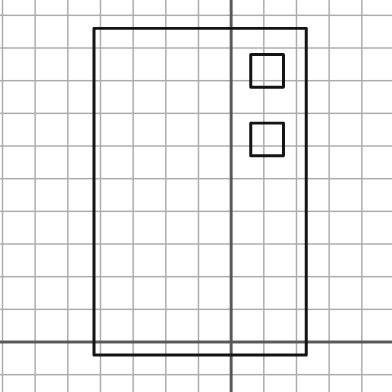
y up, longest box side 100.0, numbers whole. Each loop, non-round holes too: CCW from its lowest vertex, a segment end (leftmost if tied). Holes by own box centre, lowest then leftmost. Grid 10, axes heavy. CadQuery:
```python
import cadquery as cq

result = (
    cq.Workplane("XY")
    .moveTo(-42.0, -4.0)
    .lineTo(23.0, -4.0)
    .lineTo(23.0, 96.0)
    .lineTo(-42.0, 96.0)
    .close()
    .moveTo(6.0, 57.0)
    .lineTo(16.0, 57.0)
    .lineTo(16.0, 67.0)
    .lineTo(6.0, 67.0)
    .close()
    .moveTo(6.0, 78.0)
    .lineTo(16.0, 78.0)
    .lineTo(16.0, 88.0)
    .lineTo(6.0, 88.0)
    .close()
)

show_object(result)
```